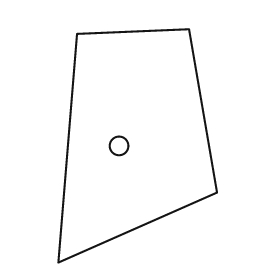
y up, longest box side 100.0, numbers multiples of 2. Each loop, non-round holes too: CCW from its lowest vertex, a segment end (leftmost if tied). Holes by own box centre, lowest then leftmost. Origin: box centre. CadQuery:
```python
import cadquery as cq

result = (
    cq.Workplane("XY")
    .moveTo(-34.0, -50.0)
    .lineTo(34.0, -20.0)
    .lineTo(22.0, 50.0)
    .lineTo(-26.0, 48.0)
    .close()
    .moveTo(-8.0, 0.0)
    .circle(4.0)
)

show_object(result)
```